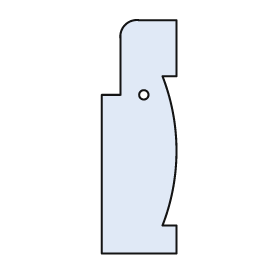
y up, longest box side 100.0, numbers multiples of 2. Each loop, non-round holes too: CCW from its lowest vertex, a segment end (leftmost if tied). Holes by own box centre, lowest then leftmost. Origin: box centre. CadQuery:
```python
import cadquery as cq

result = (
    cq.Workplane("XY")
    .moveTo(-16.0, -50.0)
    .lineTo(16.0, -50.0)
    .lineTo(16.0, -38.0)
    .lineTo(10.0, -38.0)
    .threePointArc((16.0, -6.0), (10.0, 26.0))
    .lineTo(16.0, 26.0)
    .lineTo(16.0, 50.0)
    .lineTo(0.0, 50.0)
    .threePointArc((-6.0, 48.0), (-8.0, 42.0))
    .lineTo(-8.0, 18.0)
    .lineTo(-16.0, 18.0)
    .close()
    .moveTo(2.0, 18.0)
    .circle(2.0)
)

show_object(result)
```